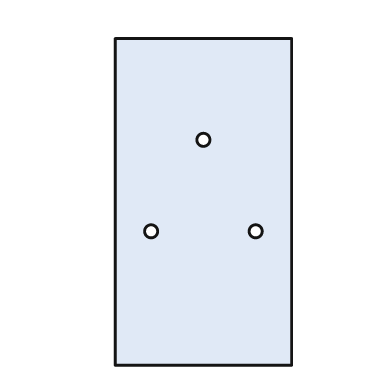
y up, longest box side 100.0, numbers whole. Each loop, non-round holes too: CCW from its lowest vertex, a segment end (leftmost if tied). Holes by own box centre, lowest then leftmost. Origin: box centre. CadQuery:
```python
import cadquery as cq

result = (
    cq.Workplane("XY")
    .moveTo(-27.0, -50.0)
    .lineTo(27.0, -50.0)
    .lineTo(27.0, 50.0)
    .lineTo(-27.0, 50.0)
    .close()
    .moveTo(-16.0, -9.0)
    .circle(2.0)
    .moveTo(16.0, -9.0)
    .circle(2.0)
    .moveTo(0.0, 19.0)
    .circle(2.0)
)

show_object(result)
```